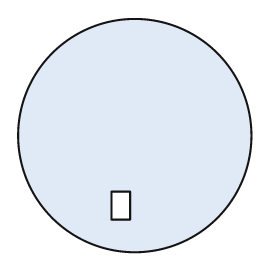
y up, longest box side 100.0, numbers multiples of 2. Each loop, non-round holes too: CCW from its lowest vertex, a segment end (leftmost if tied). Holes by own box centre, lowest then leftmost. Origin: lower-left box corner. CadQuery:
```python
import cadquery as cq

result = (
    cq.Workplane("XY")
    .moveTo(50.0, 50.0)
    .circle(50.0)
    .moveTo(40.0, 14.0)
    .lineTo(48.0, 14.0)
    .lineTo(48.0, 26.0)
    .lineTo(40.0, 26.0)
    .close()
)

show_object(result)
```